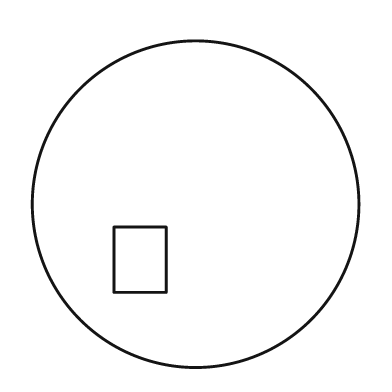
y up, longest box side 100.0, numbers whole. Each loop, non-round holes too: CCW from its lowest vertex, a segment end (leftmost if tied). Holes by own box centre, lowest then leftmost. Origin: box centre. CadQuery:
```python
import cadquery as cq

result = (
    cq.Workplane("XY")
    .moveTo(0.0, 0.0)
    .circle(50.0)
    .moveTo(-25.0, -27.0)
    .lineTo(-9.0, -27.0)
    .lineTo(-9.0, -7.0)
    .lineTo(-25.0, -7.0)
    .close()
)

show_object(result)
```